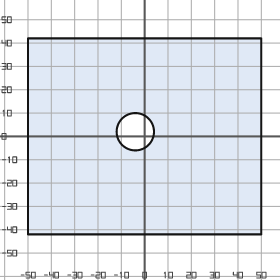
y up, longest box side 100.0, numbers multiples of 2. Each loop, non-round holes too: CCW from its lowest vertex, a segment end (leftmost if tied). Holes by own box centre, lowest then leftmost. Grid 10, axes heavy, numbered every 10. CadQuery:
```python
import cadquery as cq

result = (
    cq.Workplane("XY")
    .moveTo(-50.0, -42.0)
    .lineTo(50.0, -42.0)
    .lineTo(50.0, 42.0)
    .lineTo(-50.0, 42.0)
    .close()
    .moveTo(-4.0, 2.0)
    .circle(8.0)
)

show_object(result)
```